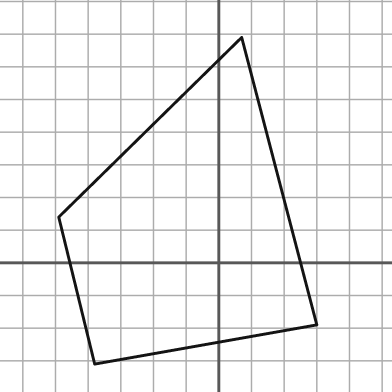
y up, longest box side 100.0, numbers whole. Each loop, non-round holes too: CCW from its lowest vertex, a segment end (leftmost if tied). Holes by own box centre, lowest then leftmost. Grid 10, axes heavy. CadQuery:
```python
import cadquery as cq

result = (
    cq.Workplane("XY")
    .moveTo(-38.0, -31.0)
    .lineTo(30.0, -19.0)
    .lineTo(7.0, 69.0)
    .lineTo(-49.0, 14.0)
    .close()
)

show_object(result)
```